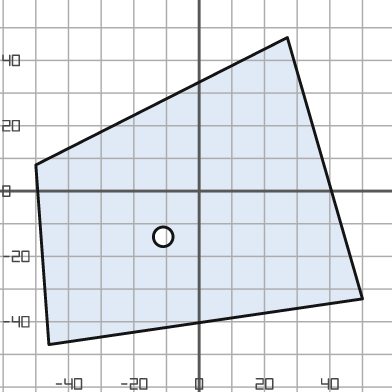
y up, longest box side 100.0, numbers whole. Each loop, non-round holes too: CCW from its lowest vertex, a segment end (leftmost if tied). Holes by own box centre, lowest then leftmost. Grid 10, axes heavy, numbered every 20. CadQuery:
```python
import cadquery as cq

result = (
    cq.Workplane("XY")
    .moveTo(-46.0, -47.0)
    .lineTo(50.0, -33.0)
    .lineTo(27.0, 47.0)
    .lineTo(-50.0, 8.0)
    .close()
    .moveTo(-11.0, -14.0)
    .circle(3.0)
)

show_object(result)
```